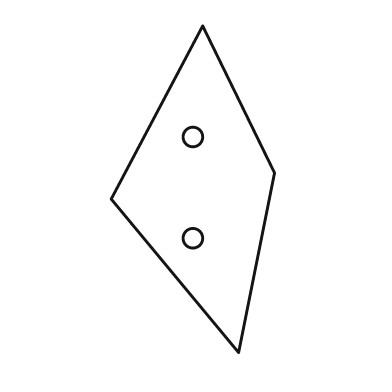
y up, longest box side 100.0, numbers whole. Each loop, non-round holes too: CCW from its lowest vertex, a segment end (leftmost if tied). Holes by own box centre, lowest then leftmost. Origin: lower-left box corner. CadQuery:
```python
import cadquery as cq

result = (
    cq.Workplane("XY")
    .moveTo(39.0, 0.0)
    .lineTo(50.0, 55.0)
    .lineTo(28.0, 100.0)
    .lineTo(0.0, 47.0)
    .close()
    .moveTo(25.0, 35.0)
    .circle(3.0)
    .moveTo(25.0, 66.0)
    .circle(3.0)
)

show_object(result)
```